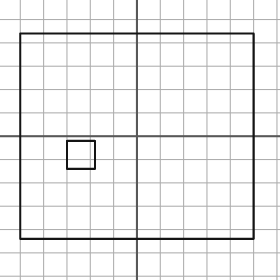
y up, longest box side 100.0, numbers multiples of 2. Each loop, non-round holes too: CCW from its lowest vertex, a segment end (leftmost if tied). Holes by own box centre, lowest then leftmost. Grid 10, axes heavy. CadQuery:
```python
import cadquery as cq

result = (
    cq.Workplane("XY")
    .moveTo(-50.0, -44.0)
    .lineTo(50.0, -44.0)
    .lineTo(50.0, 44.0)
    .lineTo(-50.0, 44.0)
    .close()
    .moveTo(-30.0, -14.0)
    .lineTo(-18.0, -14.0)
    .lineTo(-18.0, -2.0)
    .lineTo(-30.0, -2.0)
    .close()
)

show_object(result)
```